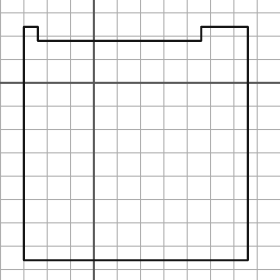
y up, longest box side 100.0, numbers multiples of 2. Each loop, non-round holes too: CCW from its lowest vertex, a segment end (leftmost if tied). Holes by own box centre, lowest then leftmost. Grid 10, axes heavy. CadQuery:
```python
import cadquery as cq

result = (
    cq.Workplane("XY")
    .moveTo(-30.0, -76.0)
    .lineTo(66.0, -76.0)
    .lineTo(66.0, 24.0)
    .lineTo(46.0, 24.0)
    .lineTo(46.0, 18.0)
    .lineTo(-24.0, 18.0)
    .lineTo(-24.0, 24.0)
    .lineTo(-30.0, 24.0)
    .close()
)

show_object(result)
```